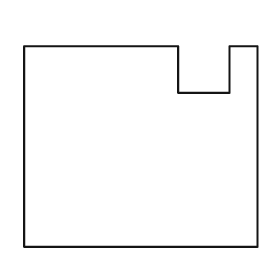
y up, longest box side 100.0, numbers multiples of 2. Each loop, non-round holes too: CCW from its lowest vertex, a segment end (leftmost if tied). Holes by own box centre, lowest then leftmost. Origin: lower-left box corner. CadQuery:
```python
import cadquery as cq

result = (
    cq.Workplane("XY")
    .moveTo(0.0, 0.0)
    .lineTo(100.0, 0.0)
    .lineTo(100.0, 86.0)
    .lineTo(88.0, 86.0)
    .lineTo(88.0, 66.0)
    .lineTo(66.0, 66.0)
    .lineTo(66.0, 86.0)
    .lineTo(0.0, 86.0)
    .close()
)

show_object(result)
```